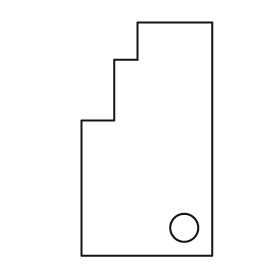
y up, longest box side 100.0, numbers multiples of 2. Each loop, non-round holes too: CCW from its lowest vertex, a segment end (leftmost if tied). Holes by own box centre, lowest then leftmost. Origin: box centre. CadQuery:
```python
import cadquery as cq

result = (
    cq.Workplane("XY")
    .moveTo(-28.0, -50.0)
    .lineTo(28.0, -50.0)
    .lineTo(28.0, 50.0)
    .lineTo(-4.0, 50.0)
    .lineTo(-4.0, 34.0)
    .lineTo(-14.0, 34.0)
    .lineTo(-14.0, 8.0)
    .lineTo(-28.0, 8.0)
    .close()
    .moveTo(16.0, -38.0)
    .circle(6.0)
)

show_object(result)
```